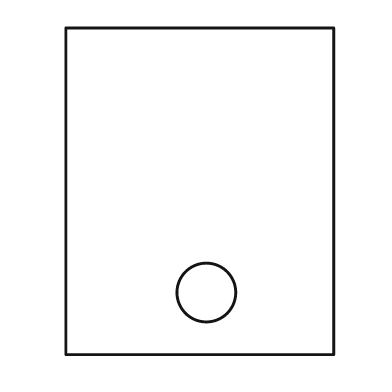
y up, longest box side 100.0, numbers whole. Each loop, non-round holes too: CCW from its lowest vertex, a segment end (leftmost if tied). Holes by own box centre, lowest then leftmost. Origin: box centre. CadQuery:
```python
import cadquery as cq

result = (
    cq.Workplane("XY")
    .moveTo(-41.0, -50.0)
    .lineTo(41.0, -50.0)
    .lineTo(41.0, 50.0)
    .lineTo(-41.0, 50.0)
    .close()
    .moveTo(2.0, -31.0)
    .circle(9.0)
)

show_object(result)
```